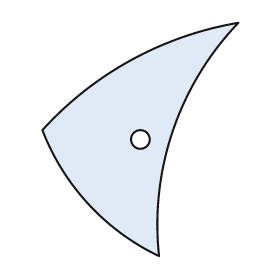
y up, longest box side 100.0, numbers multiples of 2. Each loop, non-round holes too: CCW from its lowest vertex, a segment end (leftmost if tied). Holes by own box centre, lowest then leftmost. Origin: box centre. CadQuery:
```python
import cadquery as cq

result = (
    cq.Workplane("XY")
    .moveTo(8.0, -50.0)
    .threePointArc((14.0, 4.0), (42.0, 50.0))
    .threePointArc((-4.0, 34.0), (-42.0, 4.0))
    .threePointArc((-22.0, -28.0), (8.0, -50.0))
    .close()
    .moveTo(0.0, 0.0)
    .circle(4.0)
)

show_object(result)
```